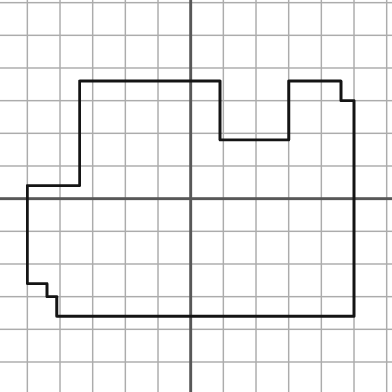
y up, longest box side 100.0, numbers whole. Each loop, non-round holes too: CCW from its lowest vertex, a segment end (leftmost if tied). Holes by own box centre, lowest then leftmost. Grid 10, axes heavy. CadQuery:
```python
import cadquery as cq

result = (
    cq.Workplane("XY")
    .moveTo(-41.0, -36.0)
    .lineTo(50.0, -36.0)
    .lineTo(50.0, 30.0)
    .lineTo(46.0, 30.0)
    .lineTo(46.0, 36.0)
    .lineTo(30.0, 36.0)
    .lineTo(30.0, 18.0)
    .lineTo(9.0, 18.0)
    .lineTo(9.0, 36.0)
    .lineTo(-34.0, 36.0)
    .lineTo(-34.0, 4.0)
    .lineTo(-50.0, 4.0)
    .lineTo(-50.0, -26.0)
    .lineTo(-44.0, -26.0)
    .lineTo(-44.0, -30.0)
    .lineTo(-41.0, -30.0)
    .close()
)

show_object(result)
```